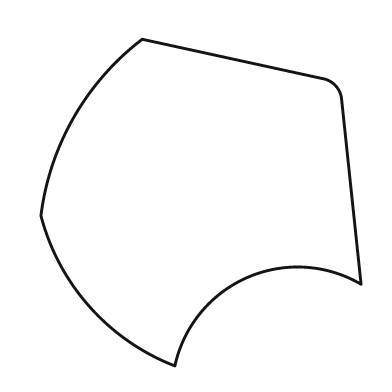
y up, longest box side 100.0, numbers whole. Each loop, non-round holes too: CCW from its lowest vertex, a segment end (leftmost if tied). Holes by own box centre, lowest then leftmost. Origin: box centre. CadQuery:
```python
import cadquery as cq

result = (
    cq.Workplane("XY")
    .moveTo(-8.0, -50.0)
    .threePointArc((14.0, -23.0), (49.0, -25.0))
    .lineTo(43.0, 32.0)
    .threePointArc((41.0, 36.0), (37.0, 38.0))
    .lineTo(-18.0, 50.0)
    .threePointArc((-39.0, 26.0), (-49.0, -4.0))
    .threePointArc((-34.0, -32.0), (-8.0, -50.0))
    .close()
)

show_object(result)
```